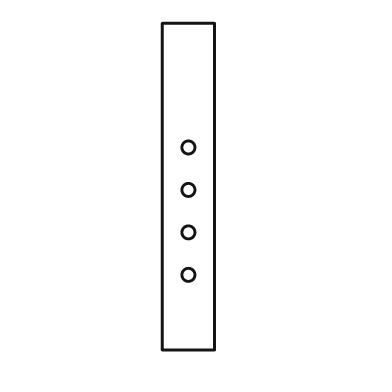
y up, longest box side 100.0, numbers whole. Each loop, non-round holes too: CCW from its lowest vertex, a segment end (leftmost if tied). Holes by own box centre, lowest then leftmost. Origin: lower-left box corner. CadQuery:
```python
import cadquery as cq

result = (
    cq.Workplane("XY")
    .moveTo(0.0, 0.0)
    .lineTo(16.0, 0.0)
    .lineTo(16.0, 100.0)
    .lineTo(0.0, 100.0)
    .close()
    .moveTo(8.0, 23.0)
    .circle(2.0)
    .moveTo(8.0, 36.0)
    .circle(2.0)
    .moveTo(8.0, 49.0)
    .circle(2.0)
    .moveTo(8.0, 62.0)
    .circle(2.0)
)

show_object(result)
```